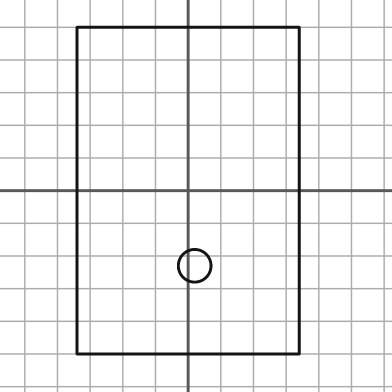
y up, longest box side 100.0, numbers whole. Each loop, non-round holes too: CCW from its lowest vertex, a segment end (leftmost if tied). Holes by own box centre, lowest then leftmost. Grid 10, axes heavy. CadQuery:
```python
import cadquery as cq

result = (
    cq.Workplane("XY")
    .moveTo(-34.0, -50.0)
    .lineTo(34.0, -50.0)
    .lineTo(34.0, 50.0)
    .lineTo(-34.0, 50.0)
    .close()
    .moveTo(2.0, -23.0)
    .circle(5.0)
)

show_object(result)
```